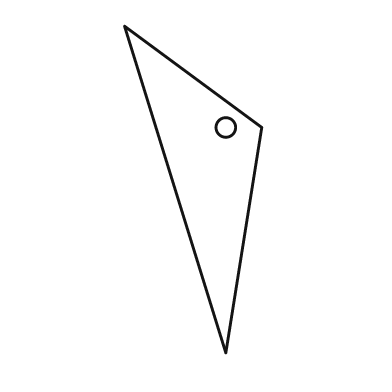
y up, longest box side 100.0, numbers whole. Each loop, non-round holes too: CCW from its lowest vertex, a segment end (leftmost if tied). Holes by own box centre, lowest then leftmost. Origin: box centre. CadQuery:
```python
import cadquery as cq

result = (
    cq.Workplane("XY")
    .moveTo(10.0, -50.0)
    .lineTo(21.0, 19.0)
    .lineTo(-21.0, 50.0)
    .close()
    .moveTo(10.0, 19.0)
    .circle(3.0)
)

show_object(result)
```